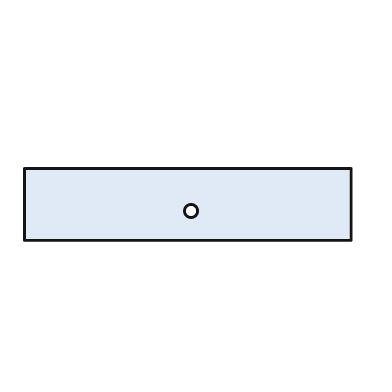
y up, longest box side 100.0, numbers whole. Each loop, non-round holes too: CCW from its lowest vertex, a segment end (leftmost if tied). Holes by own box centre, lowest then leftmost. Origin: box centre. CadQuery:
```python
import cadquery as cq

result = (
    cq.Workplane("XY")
    .moveTo(-50.0, -11.0)
    .lineTo(50.0, -11.0)
    .lineTo(50.0, 11.0)
    .lineTo(-50.0, 11.0)
    .close()
    .moveTo(1.0, -2.0)
    .circle(2.0)
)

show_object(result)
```